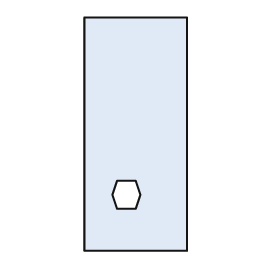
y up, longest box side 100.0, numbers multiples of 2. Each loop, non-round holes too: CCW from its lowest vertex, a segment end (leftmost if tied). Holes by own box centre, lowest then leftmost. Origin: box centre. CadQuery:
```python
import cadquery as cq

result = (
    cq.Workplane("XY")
    .moveTo(-22.0, -50.0)
    .lineTo(22.0, -50.0)
    .lineTo(22.0, 50.0)
    .lineTo(-22.0, 50.0)
    .close()
    .moveTo(-8.0, -32.0)
    .lineTo(0.0, -32.0)
    .lineTo(2.0, -26.0)
    .lineTo(0.0, -20.0)
    .lineTo(-8.0, -20.0)
    .lineTo(-10.0, -26.0)
    .close()
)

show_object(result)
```